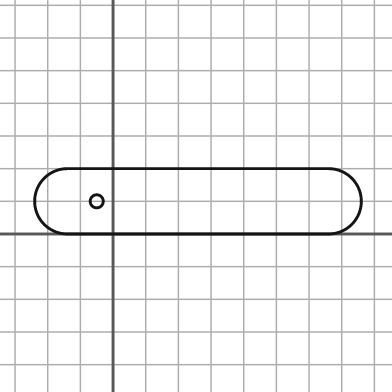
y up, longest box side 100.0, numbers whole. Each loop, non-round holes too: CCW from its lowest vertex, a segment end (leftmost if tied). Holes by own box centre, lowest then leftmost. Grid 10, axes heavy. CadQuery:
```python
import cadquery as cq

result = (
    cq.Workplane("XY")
    .moveTo(-14.0, 0.0)
    .lineTo(66.0, 0.0)
    .threePointArc((76.0, 10.0), (66.0, 20.0))
    .lineTo(-14.0, 20.0)
    .threePointArc((-24.0, 10.0), (-14.0, 0.0))
    .close()
    .moveTo(-5.0, 10.0)
    .circle(2.0)
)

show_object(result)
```